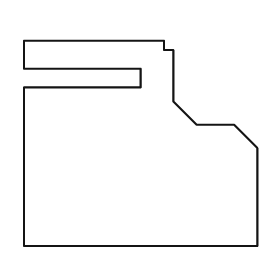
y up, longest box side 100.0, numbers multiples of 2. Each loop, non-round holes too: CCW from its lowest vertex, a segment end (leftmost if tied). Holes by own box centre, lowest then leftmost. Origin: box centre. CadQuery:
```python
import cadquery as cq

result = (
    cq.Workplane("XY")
    .moveTo(-50.0, -44.0)
    .lineTo(50.0, -44.0)
    .lineTo(50.0, -2.0)
    .lineTo(40.0, 8.0)
    .lineTo(24.0, 8.0)
    .lineTo(14.0, 18.0)
    .lineTo(14.0, 40.0)
    .lineTo(10.0, 40.0)
    .lineTo(10.0, 44.0)
    .lineTo(-50.0, 44.0)
    .lineTo(-50.0, 32.0)
    .lineTo(0.0, 32.0)
    .lineTo(0.0, 24.0)
    .lineTo(-50.0, 24.0)
    .close()
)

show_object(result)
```